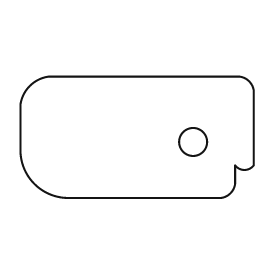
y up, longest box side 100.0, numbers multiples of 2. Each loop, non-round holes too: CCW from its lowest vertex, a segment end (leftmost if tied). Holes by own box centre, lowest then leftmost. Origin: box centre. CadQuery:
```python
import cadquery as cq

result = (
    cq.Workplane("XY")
    .moveTo(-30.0, -26.0)
    .lineTo(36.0, -26.0)
    .threePointArc((40.0, -24.0), (42.0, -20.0))
    .lineTo(42.0, -12.0)
    .threePointArc((46.0, -14.0), (50.0, -12.0))
    .lineTo(50.0, 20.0)
    .threePointArc((48.0, 24.0), (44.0, 26.0))
    .lineTo(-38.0, 26.0)
    .threePointArc((-46.0, 22.0), (-50.0, 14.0))
    .lineTo(-50.0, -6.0)
    .threePointArc((-44.0, -20.0), (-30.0, -26.0))
    .close()
    .moveTo(24.0, -2.0)
    .circle(6.0)
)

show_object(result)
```